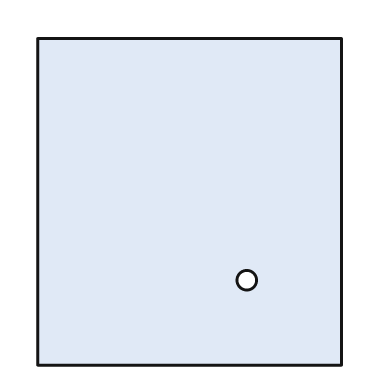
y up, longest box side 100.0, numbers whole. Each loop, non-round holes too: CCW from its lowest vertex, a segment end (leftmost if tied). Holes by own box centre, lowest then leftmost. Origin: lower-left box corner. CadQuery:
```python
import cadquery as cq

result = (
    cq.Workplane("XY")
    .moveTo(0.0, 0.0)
    .lineTo(93.0, 0.0)
    .lineTo(93.0, 100.0)
    .lineTo(0.0, 100.0)
    .close()
    .moveTo(64.0, 26.0)
    .circle(3.0)
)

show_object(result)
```